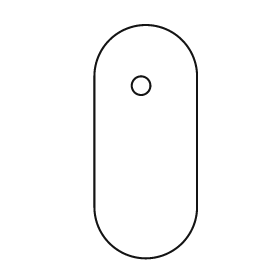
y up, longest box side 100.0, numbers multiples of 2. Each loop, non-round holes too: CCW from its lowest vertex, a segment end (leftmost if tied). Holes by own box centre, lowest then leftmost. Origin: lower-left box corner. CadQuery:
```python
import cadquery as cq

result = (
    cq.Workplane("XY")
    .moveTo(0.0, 22.0)
    .threePointArc((22.0, 0.0), (44.0, 22.0))
    .lineTo(44.0, 78.0)
    .threePointArc((22.0, 100.0), (0.0, 78.0))
    .close()
    .moveTo(20.0, 74.0)
    .circle(4.0)
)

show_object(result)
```